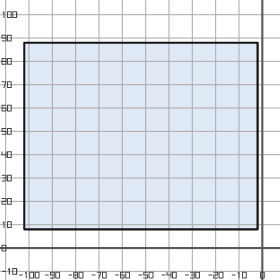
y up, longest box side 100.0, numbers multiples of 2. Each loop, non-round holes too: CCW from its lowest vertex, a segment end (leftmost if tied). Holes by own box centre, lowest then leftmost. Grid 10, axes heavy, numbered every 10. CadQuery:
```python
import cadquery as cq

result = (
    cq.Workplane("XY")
    .moveTo(-102.0, 8.0)
    .lineTo(-2.0, 8.0)
    .lineTo(-2.0, 88.0)
    .lineTo(-102.0, 88.0)
    .close()
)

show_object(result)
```